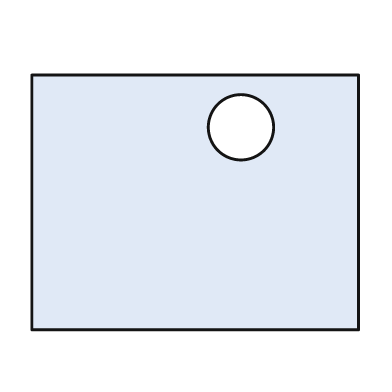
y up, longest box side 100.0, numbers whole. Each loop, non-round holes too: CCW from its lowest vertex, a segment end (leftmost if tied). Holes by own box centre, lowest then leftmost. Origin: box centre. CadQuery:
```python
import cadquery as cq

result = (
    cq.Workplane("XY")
    .moveTo(-50.0, -39.0)
    .lineTo(50.0, -39.0)
    .lineTo(50.0, 39.0)
    .lineTo(-50.0, 39.0)
    .close()
    .moveTo(14.0, 23.0)
    .circle(10.0)
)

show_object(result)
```